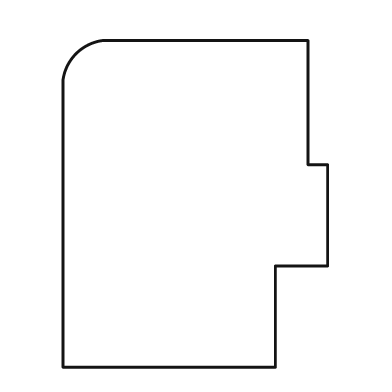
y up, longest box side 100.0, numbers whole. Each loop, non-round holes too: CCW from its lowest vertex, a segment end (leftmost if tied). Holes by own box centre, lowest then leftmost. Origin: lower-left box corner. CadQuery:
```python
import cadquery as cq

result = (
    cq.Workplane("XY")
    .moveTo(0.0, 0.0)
    .lineTo(65.0, 0.0)
    .lineTo(65.0, 31.0)
    .lineTo(81.0, 31.0)
    .lineTo(81.0, 62.0)
    .lineTo(75.0, 62.0)
    .lineTo(75.0, 100.0)
    .lineTo(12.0, 100.0)
    .threePointArc((4.0, 96.0), (0.0, 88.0))
    .close()
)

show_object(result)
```